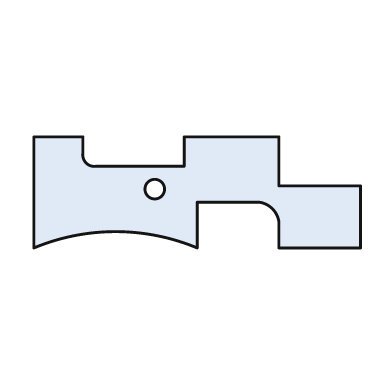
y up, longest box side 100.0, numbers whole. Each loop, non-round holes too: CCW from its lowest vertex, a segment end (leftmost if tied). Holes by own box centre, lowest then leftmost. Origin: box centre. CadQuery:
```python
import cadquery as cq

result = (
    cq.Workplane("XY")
    .moveTo(-50.0, -17.0)
    .threePointArc((-25.0, -12.0), (0.0, -17.0))
    .lineTo(0.0, -3.0)
    .lineTo(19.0, -3.0)
    .threePointArc((23.0, -5.0), (25.0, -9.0))
    .lineTo(25.0, -17.0)
    .lineTo(50.0, -17.0)
    .lineTo(50.0, 2.0)
    .lineTo(25.0, 2.0)
    .lineTo(25.0, 17.0)
    .lineTo(-4.0, 17.0)
    .lineTo(-4.0, 8.0)
    .lineTo(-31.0, 8.0)
    .threePointArc((-34.0, 9.0), (-35.0, 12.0))
    .lineTo(-35.0, 17.0)
    .lineTo(-50.0, 17.0)
    .close()
    .moveTo(-13.0, 1.0)
    .circle(3.0)
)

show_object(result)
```